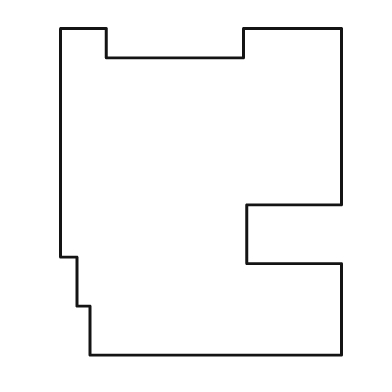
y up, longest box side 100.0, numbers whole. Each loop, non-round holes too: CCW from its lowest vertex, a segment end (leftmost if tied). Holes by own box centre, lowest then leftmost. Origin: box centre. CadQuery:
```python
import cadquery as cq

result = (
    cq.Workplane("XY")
    .moveTo(-34.0, -50.0)
    .lineTo(43.0, -50.0)
    .lineTo(43.0, -22.0)
    .lineTo(14.0, -22.0)
    .lineTo(14.0, -4.0)
    .lineTo(43.0, -4.0)
    .lineTo(43.0, 50.0)
    .lineTo(13.0, 50.0)
    .lineTo(13.0, 41.0)
    .lineTo(-29.0, 41.0)
    .lineTo(-29.0, 50.0)
    .lineTo(-43.0, 50.0)
    .lineTo(-43.0, -20.0)
    .lineTo(-38.0, -20.0)
    .lineTo(-38.0, -35.0)
    .lineTo(-34.0, -35.0)
    .close()
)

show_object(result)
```